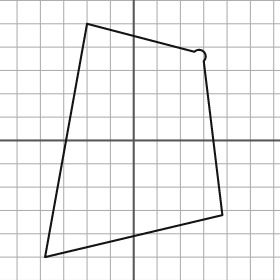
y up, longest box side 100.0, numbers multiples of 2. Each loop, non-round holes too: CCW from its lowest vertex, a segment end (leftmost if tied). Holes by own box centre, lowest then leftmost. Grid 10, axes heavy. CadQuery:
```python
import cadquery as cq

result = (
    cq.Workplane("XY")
    .moveTo(-38.0, -50.0)
    .lineTo(38.0, -32.0)
    .lineTo(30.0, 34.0)
    .threePointArc((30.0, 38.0), (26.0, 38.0))
    .lineTo(-20.0, 50.0)
    .close()
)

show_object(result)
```